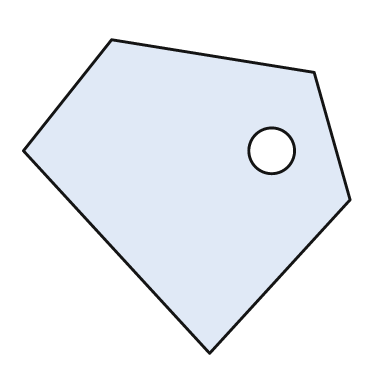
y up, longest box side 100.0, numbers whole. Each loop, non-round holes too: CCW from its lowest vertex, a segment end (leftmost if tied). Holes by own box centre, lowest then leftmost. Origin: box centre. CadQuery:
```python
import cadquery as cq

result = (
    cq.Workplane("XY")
    .moveTo(7.0, -48.0)
    .lineTo(50.0, -1.0)
    .lineTo(39.0, 38.0)
    .lineTo(-23.0, 48.0)
    .lineTo(-50.0, 14.0)
    .close()
    .moveTo(26.0, 14.0)
    .circle(7.0)
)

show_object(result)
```